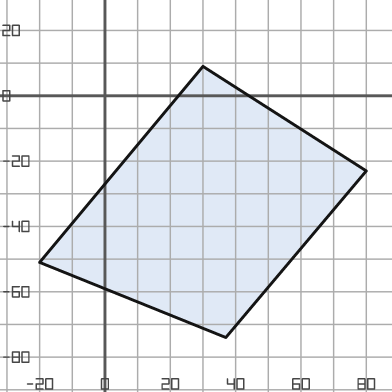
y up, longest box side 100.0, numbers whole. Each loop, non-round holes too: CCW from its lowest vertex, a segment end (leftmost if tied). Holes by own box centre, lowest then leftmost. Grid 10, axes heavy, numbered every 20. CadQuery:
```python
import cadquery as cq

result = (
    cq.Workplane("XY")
    .moveTo(37.0, -74.0)
    .lineTo(80.0, -23.0)
    .lineTo(30.0, 9.0)
    .lineTo(-20.0, -51.0)
    .close()
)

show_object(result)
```